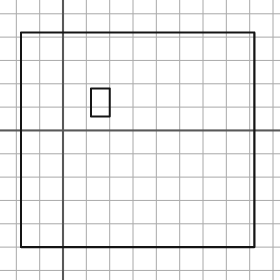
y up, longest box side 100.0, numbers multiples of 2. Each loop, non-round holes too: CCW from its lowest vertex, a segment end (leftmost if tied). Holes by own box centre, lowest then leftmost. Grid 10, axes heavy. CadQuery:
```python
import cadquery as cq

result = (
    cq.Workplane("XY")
    .moveTo(-18.0, -50.0)
    .lineTo(82.0, -50.0)
    .lineTo(82.0, 42.0)
    .lineTo(-18.0, 42.0)
    .close()
    .moveTo(12.0, 6.0)
    .lineTo(20.0, 6.0)
    .lineTo(20.0, 18.0)
    .lineTo(12.0, 18.0)
    .close()
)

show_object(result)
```